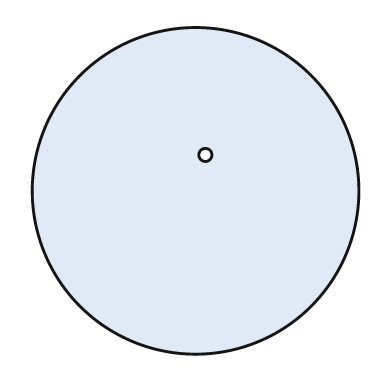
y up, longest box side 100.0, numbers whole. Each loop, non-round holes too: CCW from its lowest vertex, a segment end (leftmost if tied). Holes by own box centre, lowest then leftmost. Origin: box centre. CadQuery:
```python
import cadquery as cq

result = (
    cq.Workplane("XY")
    .moveTo(0.0, 0.0)
    .circle(50.0)
    .moveTo(3.0, 11.0)
    .circle(2.0)
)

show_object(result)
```